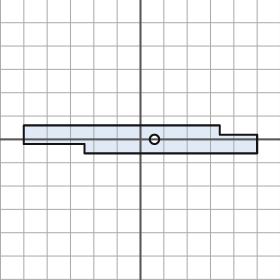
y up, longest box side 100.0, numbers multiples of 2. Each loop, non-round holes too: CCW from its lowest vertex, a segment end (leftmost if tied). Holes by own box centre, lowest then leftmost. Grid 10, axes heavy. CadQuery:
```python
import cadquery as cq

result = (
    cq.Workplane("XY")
    .moveTo(-24.0, -6.0)
    .lineTo(50.0, -6.0)
    .lineTo(50.0, 2.0)
    .lineTo(34.0, 2.0)
    .lineTo(34.0, 6.0)
    .lineTo(-50.0, 6.0)
    .lineTo(-50.0, -2.0)
    .lineTo(-24.0, -2.0)
    .close()
    .moveTo(6.0, 0.0)
    .circle(2.0)
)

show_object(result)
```